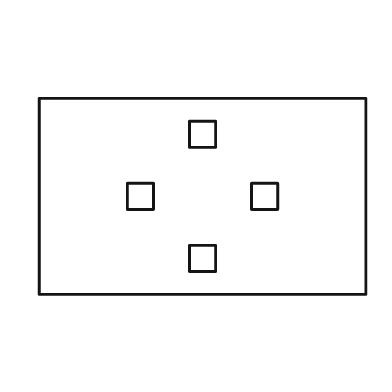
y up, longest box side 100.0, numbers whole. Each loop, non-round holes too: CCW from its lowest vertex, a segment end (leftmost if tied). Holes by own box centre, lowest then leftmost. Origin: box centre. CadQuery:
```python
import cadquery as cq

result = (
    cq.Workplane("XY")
    .moveTo(-50.0, -30.0)
    .lineTo(50.0, -30.0)
    .lineTo(50.0, 30.0)
    .lineTo(-50.0, 30.0)
    .close()
    .moveTo(-4.0, -23.0)
    .lineTo(4.0, -23.0)
    .lineTo(4.0, -15.0)
    .lineTo(-4.0, -15.0)
    .close()
    .moveTo(-23.0, -4.0)
    .lineTo(-15.0, -4.0)
    .lineTo(-15.0, 4.0)
    .lineTo(-23.0, 4.0)
    .close()
    .moveTo(15.0, -4.0)
    .lineTo(23.0, -4.0)
    .lineTo(23.0, 4.0)
    .lineTo(15.0, 4.0)
    .close()
    .moveTo(-4.0, 15.0)
    .lineTo(4.0, 15.0)
    .lineTo(4.0, 23.0)
    .lineTo(-4.0, 23.0)
    .close()
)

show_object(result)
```